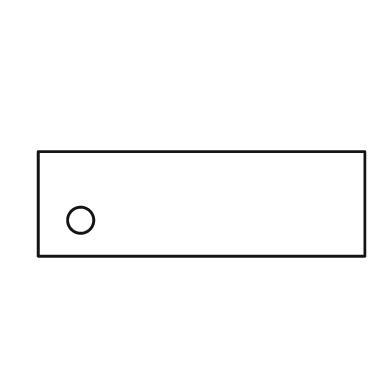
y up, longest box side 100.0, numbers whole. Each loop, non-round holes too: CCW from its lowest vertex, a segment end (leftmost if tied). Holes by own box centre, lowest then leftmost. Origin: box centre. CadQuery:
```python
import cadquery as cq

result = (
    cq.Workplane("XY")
    .moveTo(-50.0, -16.0)
    .lineTo(50.0, -16.0)
    .lineTo(50.0, 16.0)
    .lineTo(-50.0, 16.0)
    .close()
    .moveTo(-37.0, -5.0)
    .circle(4.0)
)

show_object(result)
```